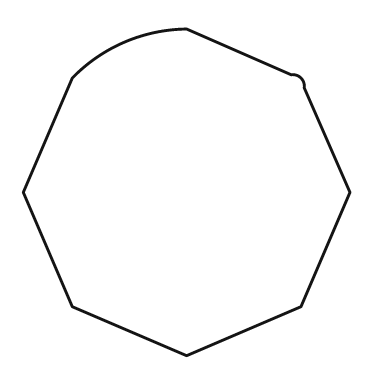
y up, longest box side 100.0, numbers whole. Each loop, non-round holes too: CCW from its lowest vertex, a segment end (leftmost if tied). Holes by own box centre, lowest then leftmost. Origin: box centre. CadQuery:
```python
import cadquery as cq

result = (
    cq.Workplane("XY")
    .moveTo(0.0, -50.0)
    .lineTo(35.0, -35.0)
    .lineTo(50.0, 0.0)
    .lineTo(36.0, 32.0)
    .threePointArc((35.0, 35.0), (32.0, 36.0))
    .lineTo(0.0, 50.0)
    .threePointArc((-19.0, 46.0), (-35.0, 35.0))
    .lineTo(-50.0, 0.0)
    .lineTo(-35.0, -35.0)
    .close()
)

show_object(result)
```